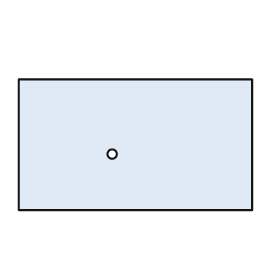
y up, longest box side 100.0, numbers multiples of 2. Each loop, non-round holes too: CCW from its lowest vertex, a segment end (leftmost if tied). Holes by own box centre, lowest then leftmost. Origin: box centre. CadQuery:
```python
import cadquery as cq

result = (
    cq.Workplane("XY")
    .moveTo(-50.0, -28.0)
    .lineTo(50.0, -28.0)
    .lineTo(50.0, 28.0)
    .lineTo(-50.0, 28.0)
    .close()
    .moveTo(-10.0, -4.0)
    .circle(2.0)
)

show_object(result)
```